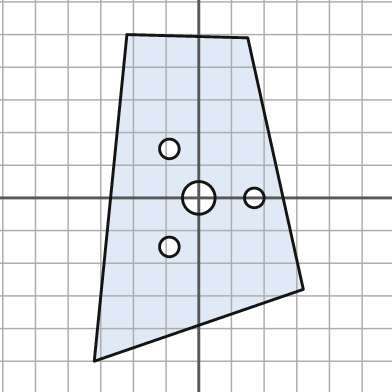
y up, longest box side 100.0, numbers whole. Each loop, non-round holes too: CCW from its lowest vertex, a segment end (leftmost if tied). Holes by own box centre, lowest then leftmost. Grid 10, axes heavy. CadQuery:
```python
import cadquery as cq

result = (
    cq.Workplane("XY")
    .moveTo(-32.0, -50.0)
    .lineTo(32.0, -28.0)
    .lineTo(15.0, 49.0)
    .lineTo(-22.0, 50.0)
    .close()
    .moveTo(-9.0, -15.0)
    .circle(3.0)
    .moveTo(0.0, 0.0)
    .circle(5.0)
    .moveTo(17.0, 0.0)
    .circle(3.0)
    .moveTo(-9.0, 15.0)
    .circle(3.0)
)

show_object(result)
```